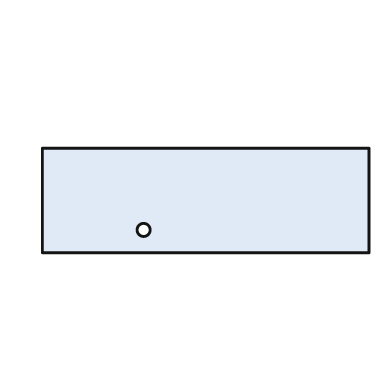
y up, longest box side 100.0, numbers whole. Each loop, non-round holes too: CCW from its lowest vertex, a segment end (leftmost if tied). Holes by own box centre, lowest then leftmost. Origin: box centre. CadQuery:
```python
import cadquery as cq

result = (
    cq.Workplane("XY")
    .moveTo(-50.0, -16.0)
    .lineTo(50.0, -16.0)
    .lineTo(50.0, 16.0)
    .lineTo(-50.0, 16.0)
    .close()
    .moveTo(-19.0, -9.0)
    .circle(2.0)
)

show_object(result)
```